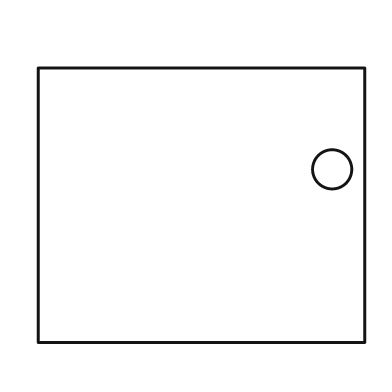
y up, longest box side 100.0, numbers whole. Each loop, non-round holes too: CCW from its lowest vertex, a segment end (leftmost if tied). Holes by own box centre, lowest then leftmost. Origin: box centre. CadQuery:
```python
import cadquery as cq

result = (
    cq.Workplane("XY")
    .moveTo(-50.0, -42.0)
    .lineTo(50.0, -42.0)
    .lineTo(50.0, 42.0)
    .lineTo(-50.0, 42.0)
    .close()
    .moveTo(40.0, 11.0)
    .circle(6.0)
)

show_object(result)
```